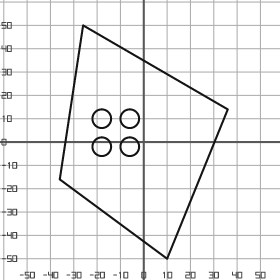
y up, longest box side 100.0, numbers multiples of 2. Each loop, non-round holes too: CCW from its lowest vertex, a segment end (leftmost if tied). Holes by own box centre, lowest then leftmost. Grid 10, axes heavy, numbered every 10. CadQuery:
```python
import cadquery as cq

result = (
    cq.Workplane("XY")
    .moveTo(10.0, -50.0)
    .lineTo(36.0, 14.0)
    .lineTo(-26.0, 50.0)
    .lineTo(-36.0, -16.0)
    .close()
    .moveTo(-18.0, -2.0)
    .circle(4.0)
    .moveTo(-6.0, -2.0)
    .circle(4.0)
    .moveTo(-18.0, 10.0)
    .circle(4.0)
    .moveTo(-6.0, 10.0)
    .circle(4.0)
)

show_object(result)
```